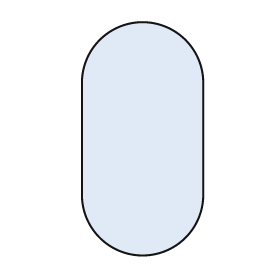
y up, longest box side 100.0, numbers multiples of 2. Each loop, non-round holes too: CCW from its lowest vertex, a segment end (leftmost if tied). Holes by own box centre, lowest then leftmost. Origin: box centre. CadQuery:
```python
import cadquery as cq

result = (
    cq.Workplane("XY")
    .moveTo(-26.0, -24.0)
    .threePointArc((0.0, -50.0), (26.0, -24.0))
    .lineTo(26.0, 24.0)
    .threePointArc((0.0, 50.0), (-26.0, 24.0))
    .close()
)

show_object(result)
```